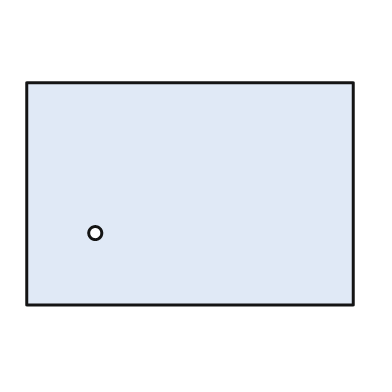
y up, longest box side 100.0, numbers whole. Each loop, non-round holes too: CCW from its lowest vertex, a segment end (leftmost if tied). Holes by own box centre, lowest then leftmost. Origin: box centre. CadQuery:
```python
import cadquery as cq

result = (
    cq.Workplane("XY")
    .moveTo(-50.0, -34.0)
    .lineTo(50.0, -34.0)
    .lineTo(50.0, 34.0)
    .lineTo(-50.0, 34.0)
    .close()
    .moveTo(-29.0, -12.0)
    .circle(2.0)
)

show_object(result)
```